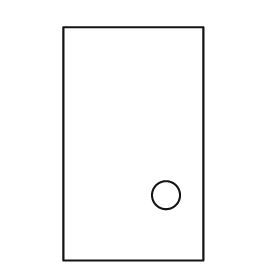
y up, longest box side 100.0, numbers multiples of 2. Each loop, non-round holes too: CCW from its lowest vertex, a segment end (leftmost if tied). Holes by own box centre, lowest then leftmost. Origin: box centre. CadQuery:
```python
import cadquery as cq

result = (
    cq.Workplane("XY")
    .moveTo(-30.0, -50.0)
    .lineTo(30.0, -50.0)
    .lineTo(30.0, 50.0)
    .lineTo(-30.0, 50.0)
    .close()
    .moveTo(14.0, -22.0)
    .circle(6.0)
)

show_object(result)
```